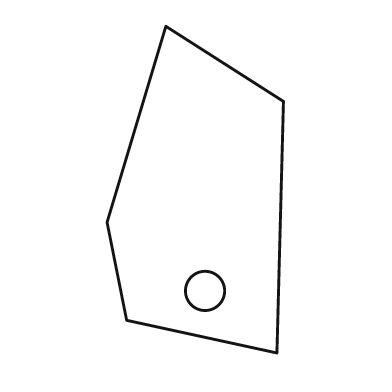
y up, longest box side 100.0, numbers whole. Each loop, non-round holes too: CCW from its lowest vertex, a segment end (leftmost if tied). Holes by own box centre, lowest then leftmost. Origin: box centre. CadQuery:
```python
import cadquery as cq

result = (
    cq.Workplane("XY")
    .moveTo(25.0, -50.0)
    .lineTo(27.0, 27.0)
    .lineTo(-9.0, 50.0)
    .lineTo(-27.0, -10.0)
    .lineTo(-21.0, -40.0)
    .close()
    .moveTo(3.0, -31.0)
    .circle(6.0)
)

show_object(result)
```